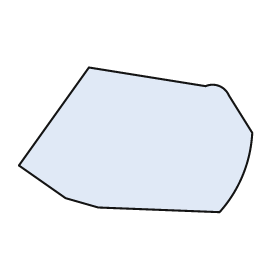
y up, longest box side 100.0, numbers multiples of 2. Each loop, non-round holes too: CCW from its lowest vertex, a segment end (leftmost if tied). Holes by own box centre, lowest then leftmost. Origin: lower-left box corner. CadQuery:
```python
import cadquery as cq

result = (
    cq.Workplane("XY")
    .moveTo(86.0, 0.0)
    .threePointArc((96.0, 16.0), (100.0, 34.0))
    .lineTo(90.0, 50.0)
    .threePointArc((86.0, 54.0), (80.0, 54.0))
    .lineTo(30.0, 62.0)
    .lineTo(0.0, 20.0)
    .lineTo(20.0, 6.0)
    .lineTo(34.0, 2.0)
    .close()
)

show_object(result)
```